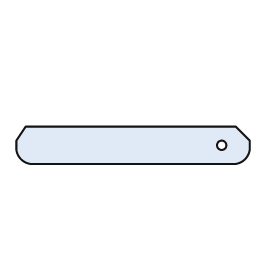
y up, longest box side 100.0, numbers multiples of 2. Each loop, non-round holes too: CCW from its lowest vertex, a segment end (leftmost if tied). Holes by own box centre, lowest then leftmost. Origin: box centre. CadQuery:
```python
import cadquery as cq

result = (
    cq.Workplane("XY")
    .moveTo(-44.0, -8.0)
    .lineTo(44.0, -8.0)
    .threePointArc((48.0, -6.0), (50.0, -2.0))
    .lineTo(50.0, 2.0)
    .lineTo(44.0, 8.0)
    .lineTo(-46.0, 8.0)
    .lineTo(-50.0, 2.0)
    .lineTo(-50.0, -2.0)
    .threePointArc((-48.0, -6.0), (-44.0, -8.0))
    .close()
    .moveTo(38.0, 0.0)
    .circle(2.0)
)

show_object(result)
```